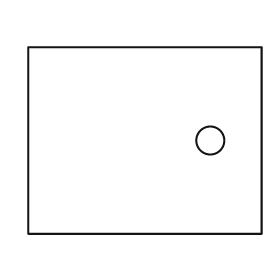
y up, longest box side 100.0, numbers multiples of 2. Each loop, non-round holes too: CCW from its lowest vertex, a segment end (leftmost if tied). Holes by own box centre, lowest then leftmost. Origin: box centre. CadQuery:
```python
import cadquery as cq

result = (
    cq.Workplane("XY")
    .moveTo(-50.0, -40.0)
    .lineTo(50.0, -40.0)
    .lineTo(50.0, 40.0)
    .lineTo(-50.0, 40.0)
    .close()
    .moveTo(28.0, 0.0)
    .circle(6.0)
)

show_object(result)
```